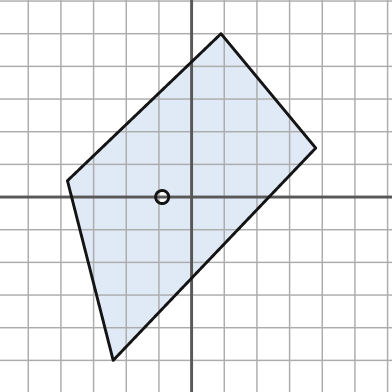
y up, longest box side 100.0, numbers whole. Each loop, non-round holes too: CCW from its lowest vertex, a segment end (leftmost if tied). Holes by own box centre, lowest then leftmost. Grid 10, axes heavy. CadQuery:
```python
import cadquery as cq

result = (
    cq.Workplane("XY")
    .moveTo(-24.0, -50.0)
    .lineTo(38.0, 15.0)
    .lineTo(9.0, 50.0)
    .lineTo(-38.0, 5.0)
    .close()
    .moveTo(-9.0, 0.0)
    .circle(2.0)
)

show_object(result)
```